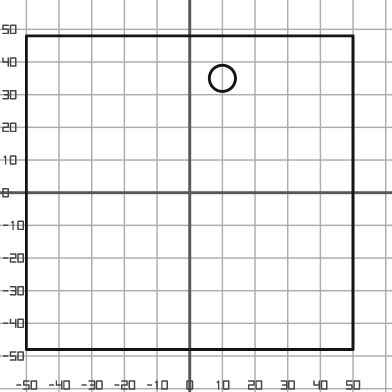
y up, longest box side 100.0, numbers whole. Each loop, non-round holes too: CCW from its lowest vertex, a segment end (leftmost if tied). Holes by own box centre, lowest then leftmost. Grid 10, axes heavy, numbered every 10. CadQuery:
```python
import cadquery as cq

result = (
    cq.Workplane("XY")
    .moveTo(-50.0, -48.0)
    .lineTo(50.0, -48.0)
    .lineTo(50.0, 48.0)
    .lineTo(-50.0, 48.0)
    .close()
    .moveTo(10.0, 35.0)
    .circle(4.0)
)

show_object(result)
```